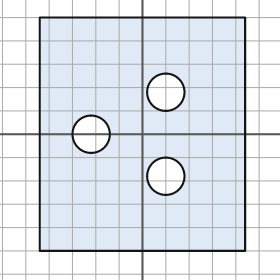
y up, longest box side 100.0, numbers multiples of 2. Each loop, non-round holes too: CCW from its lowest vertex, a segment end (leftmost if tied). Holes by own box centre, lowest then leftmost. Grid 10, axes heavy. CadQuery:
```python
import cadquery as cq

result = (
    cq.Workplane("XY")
    .moveTo(-44.0, -50.0)
    .lineTo(44.0, -50.0)
    .lineTo(44.0, 50.0)
    .lineTo(-44.0, 50.0)
    .close()
    .moveTo(10.0, -18.0)
    .circle(8.0)
    .moveTo(-22.0, 0.0)
    .circle(8.0)
    .moveTo(10.0, 18.0)
    .circle(8.0)
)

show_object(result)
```